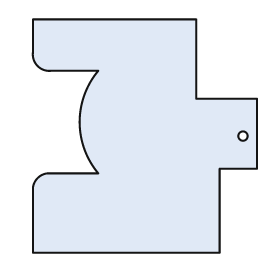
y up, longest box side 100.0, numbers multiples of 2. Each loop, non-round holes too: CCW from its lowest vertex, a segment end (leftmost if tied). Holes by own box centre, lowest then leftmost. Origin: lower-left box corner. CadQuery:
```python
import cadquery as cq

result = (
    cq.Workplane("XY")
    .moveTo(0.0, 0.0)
    .lineTo(80.0, 0.0)
    .lineTo(80.0, 36.0)
    .lineTo(96.0, 36.0)
    .lineTo(96.0, 66.0)
    .lineTo(70.0, 66.0)
    .lineTo(70.0, 100.0)
    .lineTo(0.0, 100.0)
    .lineTo(0.0, 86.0)
    .threePointArc((2.0, 80.0), (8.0, 78.0))
    .lineTo(28.0, 78.0)
    .threePointArc((20.0, 56.0), (28.0, 34.0))
    .lineTo(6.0, 34.0)
    .threePointArc((2.0, 32.0), (0.0, 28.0))
    .close()
    .moveTo(90.0, 50.0)
    .circle(2.0)
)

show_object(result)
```